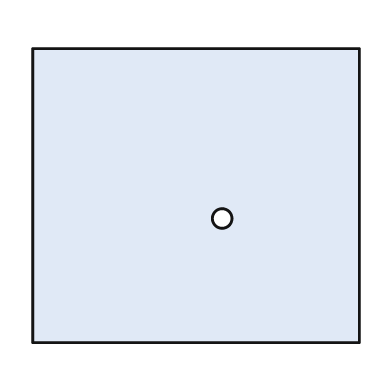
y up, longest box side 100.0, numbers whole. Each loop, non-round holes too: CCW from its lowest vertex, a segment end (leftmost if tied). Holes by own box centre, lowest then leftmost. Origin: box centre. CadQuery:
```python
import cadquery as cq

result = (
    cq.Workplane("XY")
    .moveTo(-50.0, -45.0)
    .lineTo(50.0, -45.0)
    .lineTo(50.0, 45.0)
    .lineTo(-50.0, 45.0)
    .close()
    .moveTo(8.0, -7.0)
    .circle(3.0)
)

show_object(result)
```